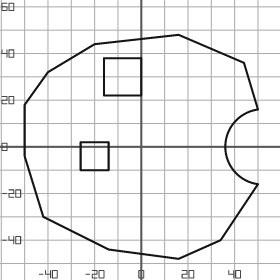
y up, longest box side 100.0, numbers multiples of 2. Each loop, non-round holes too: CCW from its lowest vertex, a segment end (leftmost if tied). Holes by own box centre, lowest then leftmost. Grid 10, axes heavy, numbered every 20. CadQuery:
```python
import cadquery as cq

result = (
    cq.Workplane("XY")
    .moveTo(16.0, -48.0)
    .lineTo(34.0, -40.0)
    .lineTo(50.0, -16.0)
    .threePointArc((36.0, 0.0), (50.0, 16.0))
    .lineTo(44.0, 36.0)
    .lineTo(16.0, 48.0)
    .lineTo(-20.0, 44.0)
    .lineTo(-40.0, 32.0)
    .lineTo(-50.0, 18.0)
    .lineTo(-50.0, -4.0)
    .lineTo(-42.0, -30.0)
    .lineTo(-14.0, -44.0)
    .close()
    .moveTo(-26.0, -10.0)
    .lineTo(-14.0, -10.0)
    .lineTo(-14.0, 2.0)
    .lineTo(-26.0, 2.0)
    .close()
    .moveTo(-16.0, 22.0)
    .lineTo(0.0, 22.0)
    .lineTo(0.0, 38.0)
    .lineTo(-16.0, 38.0)
    .close()
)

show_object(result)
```